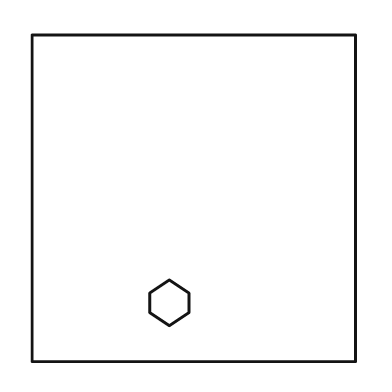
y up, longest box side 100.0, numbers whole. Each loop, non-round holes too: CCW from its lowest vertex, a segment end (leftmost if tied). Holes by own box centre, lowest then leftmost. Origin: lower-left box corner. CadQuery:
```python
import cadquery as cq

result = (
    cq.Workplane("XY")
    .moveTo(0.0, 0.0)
    .lineTo(99.0, 0.0)
    .lineTo(99.0, 100.0)
    .lineTo(0.0, 100.0)
    .close()
    .moveTo(42.0, 11.0)
    .lineTo(48.0, 15.0)
    .lineTo(48.0, 21.0)
    .lineTo(42.0, 25.0)
    .lineTo(36.0, 21.0)
    .lineTo(36.0, 15.0)
    .close()
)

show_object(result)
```